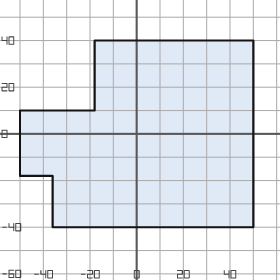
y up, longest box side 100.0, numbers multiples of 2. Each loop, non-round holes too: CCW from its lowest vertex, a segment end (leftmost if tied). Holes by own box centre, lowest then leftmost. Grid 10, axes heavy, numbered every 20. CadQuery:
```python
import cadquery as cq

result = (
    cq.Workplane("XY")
    .moveTo(-36.0, -40.0)
    .lineTo(50.0, -40.0)
    .lineTo(50.0, 40.0)
    .lineTo(-18.0, 40.0)
    .lineTo(-18.0, 10.0)
    .lineTo(-50.0, 10.0)
    .lineTo(-50.0, -18.0)
    .lineTo(-36.0, -18.0)
    .close()
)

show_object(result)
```